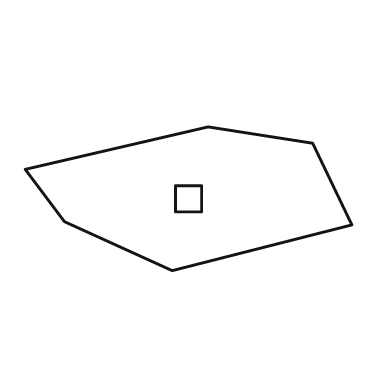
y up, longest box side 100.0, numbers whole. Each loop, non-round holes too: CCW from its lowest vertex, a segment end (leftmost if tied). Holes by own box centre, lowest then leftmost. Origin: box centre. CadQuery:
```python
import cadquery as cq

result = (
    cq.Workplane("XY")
    .moveTo(-5.0, -22.0)
    .lineTo(50.0, -8.0)
    .lineTo(38.0, 17.0)
    .lineTo(6.0, 22.0)
    .lineTo(-50.0, 9.0)
    .lineTo(-38.0, -7.0)
    .close()
    .moveTo(-4.0, -4.0)
    .lineTo(4.0, -4.0)
    .lineTo(4.0, 4.0)
    .lineTo(-4.0, 4.0)
    .close()
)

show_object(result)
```